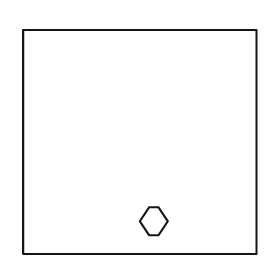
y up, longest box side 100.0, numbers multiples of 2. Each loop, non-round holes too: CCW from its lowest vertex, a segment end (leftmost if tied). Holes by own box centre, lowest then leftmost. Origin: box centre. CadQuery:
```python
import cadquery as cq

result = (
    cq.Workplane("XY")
    .moveTo(-50.0, -48.0)
    .lineTo(50.0, -48.0)
    .lineTo(50.0, 48.0)
    .lineTo(-50.0, 48.0)
    .close()
    .moveTo(4.0, -40.0)
    .lineTo(8.0, -40.0)
    .lineTo(12.0, -34.0)
    .lineTo(8.0, -28.0)
    .lineTo(4.0, -28.0)
    .lineTo(0.0, -34.0)
    .close()
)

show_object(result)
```